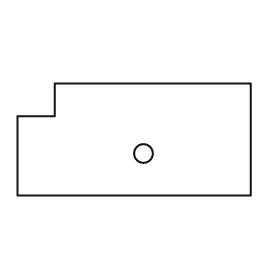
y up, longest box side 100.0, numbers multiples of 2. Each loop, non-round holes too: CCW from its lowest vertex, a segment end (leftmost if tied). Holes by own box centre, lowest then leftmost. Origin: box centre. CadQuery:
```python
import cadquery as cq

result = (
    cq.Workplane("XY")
    .moveTo(-50.0, -24.0)
    .lineTo(50.0, -24.0)
    .lineTo(50.0, 24.0)
    .lineTo(-34.0, 24.0)
    .lineTo(-34.0, 10.0)
    .lineTo(-50.0, 10.0)
    .close()
    .moveTo(4.0, -6.0)
    .circle(4.0)
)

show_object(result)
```